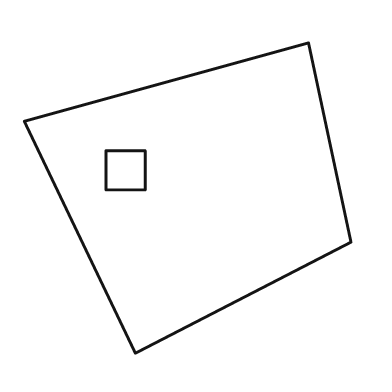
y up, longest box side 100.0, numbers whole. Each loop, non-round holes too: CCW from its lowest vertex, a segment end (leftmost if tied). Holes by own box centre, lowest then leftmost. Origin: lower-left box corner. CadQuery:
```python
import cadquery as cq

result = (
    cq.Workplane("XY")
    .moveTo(34.0, 0.0)
    .lineTo(100.0, 34.0)
    .lineTo(87.0, 95.0)
    .lineTo(0.0, 71.0)
    .close()
    .moveTo(25.0, 50.0)
    .lineTo(37.0, 50.0)
    .lineTo(37.0, 62.0)
    .lineTo(25.0, 62.0)
    .close()
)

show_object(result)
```